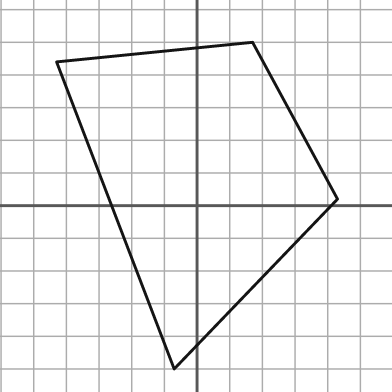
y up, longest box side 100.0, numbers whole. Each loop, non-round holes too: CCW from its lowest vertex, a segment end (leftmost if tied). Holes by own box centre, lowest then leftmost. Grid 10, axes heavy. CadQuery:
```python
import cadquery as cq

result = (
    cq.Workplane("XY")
    .moveTo(-7.0, -50.0)
    .lineTo(43.0, 2.0)
    .lineTo(17.0, 50.0)
    .lineTo(-43.0, 44.0)
    .close()
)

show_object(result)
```